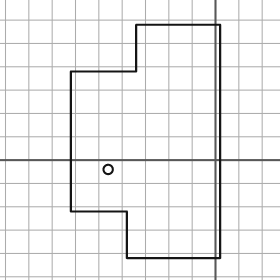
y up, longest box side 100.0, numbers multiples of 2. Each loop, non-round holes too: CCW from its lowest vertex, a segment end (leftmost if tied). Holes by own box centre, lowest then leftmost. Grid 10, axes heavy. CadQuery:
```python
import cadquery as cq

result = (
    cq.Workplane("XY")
    .moveTo(-38.0, -42.0)
    .lineTo(2.0, -42.0)
    .lineTo(2.0, 58.0)
    .lineTo(-34.0, 58.0)
    .lineTo(-34.0, 38.0)
    .lineTo(-62.0, 38.0)
    .lineTo(-62.0, -22.0)
    .lineTo(-38.0, -22.0)
    .close()
    .moveTo(-46.0, -4.0)
    .circle(2.0)
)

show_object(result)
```